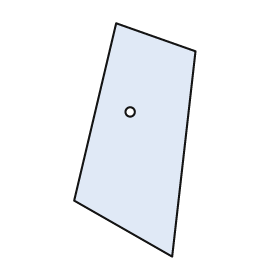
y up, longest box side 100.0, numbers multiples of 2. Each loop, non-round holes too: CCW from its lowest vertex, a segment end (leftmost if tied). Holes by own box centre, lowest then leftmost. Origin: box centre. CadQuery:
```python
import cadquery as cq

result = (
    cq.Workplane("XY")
    .moveTo(16.0, -50.0)
    .lineTo(26.0, 38.0)
    .lineTo(-8.0, 50.0)
    .lineTo(-26.0, -26.0)
    .close()
    .moveTo(-2.0, 12.0)
    .circle(2.0)
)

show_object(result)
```